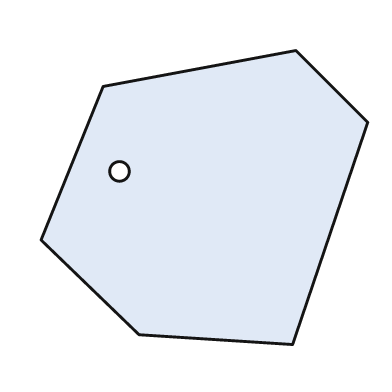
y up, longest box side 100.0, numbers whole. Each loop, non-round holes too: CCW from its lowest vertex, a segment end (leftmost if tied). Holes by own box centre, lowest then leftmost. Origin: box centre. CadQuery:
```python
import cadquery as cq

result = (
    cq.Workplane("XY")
    .moveTo(27.0, -45.0)
    .lineTo(50.0, 23.0)
    .lineTo(28.0, 45.0)
    .lineTo(-31.0, 34.0)
    .lineTo(-50.0, -13.0)
    .lineTo(-20.0, -42.0)
    .close()
    .moveTo(-26.0, 8.0)
    .circle(3.0)
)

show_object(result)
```